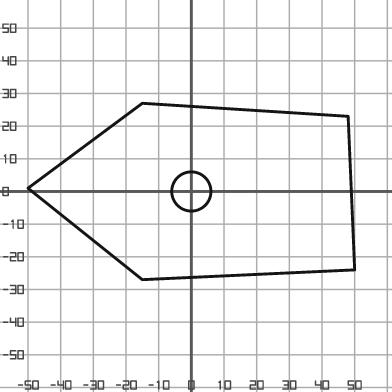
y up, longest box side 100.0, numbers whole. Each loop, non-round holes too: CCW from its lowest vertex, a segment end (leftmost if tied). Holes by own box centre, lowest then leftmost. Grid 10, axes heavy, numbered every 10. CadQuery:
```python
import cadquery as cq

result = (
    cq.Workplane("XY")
    .moveTo(-15.0, -27.0)
    .lineTo(50.0, -24.0)
    .lineTo(48.0, 23.0)
    .lineTo(-15.0, 27.0)
    .lineTo(-50.0, 1.0)
    .close()
    .moveTo(0.0, 0.0)
    .circle(6.0)
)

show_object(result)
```